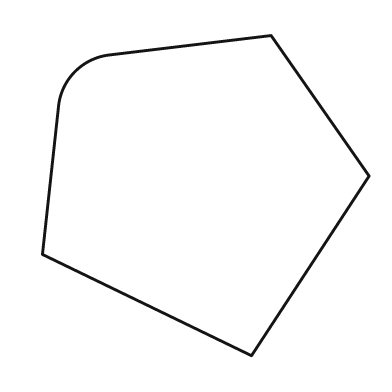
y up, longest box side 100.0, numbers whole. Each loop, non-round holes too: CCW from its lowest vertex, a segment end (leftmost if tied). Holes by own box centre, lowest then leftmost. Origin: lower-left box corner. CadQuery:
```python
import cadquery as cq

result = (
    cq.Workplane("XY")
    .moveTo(64.0, 0.0)
    .lineTo(100.0, 55.0)
    .lineTo(70.0, 98.0)
    .lineTo(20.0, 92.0)
    .threePointArc((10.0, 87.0), (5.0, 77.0))
    .lineTo(0.0, 31.0)
    .close()
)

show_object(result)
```